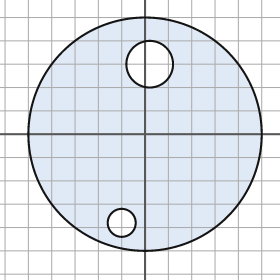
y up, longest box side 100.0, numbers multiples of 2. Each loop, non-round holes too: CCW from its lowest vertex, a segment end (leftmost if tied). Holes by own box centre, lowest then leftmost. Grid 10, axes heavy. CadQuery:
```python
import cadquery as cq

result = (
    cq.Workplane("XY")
    .moveTo(0.0, 0.0)
    .circle(50.0)
    .moveTo(-10.0, -38.0)
    .circle(6.0)
    .moveTo(2.0, 30.0)
    .circle(10.0)
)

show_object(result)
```